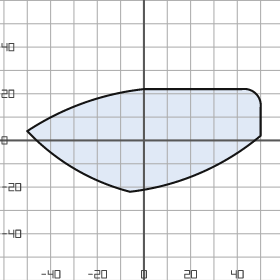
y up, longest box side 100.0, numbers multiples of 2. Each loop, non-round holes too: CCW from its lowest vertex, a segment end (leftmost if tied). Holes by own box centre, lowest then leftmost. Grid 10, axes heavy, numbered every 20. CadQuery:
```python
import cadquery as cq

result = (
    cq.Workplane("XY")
    .moveTo(-6.0, -22.0)
    .threePointArc((24.0, -14.0), (50.0, 2.0))
    .lineTo(50.0, 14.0)
    .threePointArc((48.0, 20.0), (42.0, 22.0))
    .lineTo(0.0, 22.0)
    .threePointArc((-26.0, 16.0), (-50.0, 4.0))
    .threePointArc((-30.0, -12.0), (-6.0, -22.0))
    .close()
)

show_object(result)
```